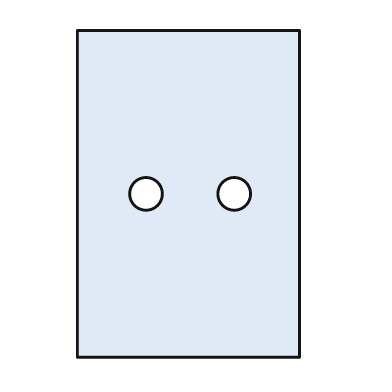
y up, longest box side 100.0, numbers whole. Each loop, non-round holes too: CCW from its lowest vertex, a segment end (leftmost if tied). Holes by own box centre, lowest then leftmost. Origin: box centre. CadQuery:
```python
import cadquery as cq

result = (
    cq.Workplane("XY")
    .moveTo(-34.0, -50.0)
    .lineTo(34.0, -50.0)
    .lineTo(34.0, 50.0)
    .lineTo(-34.0, 50.0)
    .close()
    .moveTo(-13.0, 0.0)
    .circle(5.0)
    .moveTo(14.0, 0.0)
    .circle(5.0)
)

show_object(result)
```